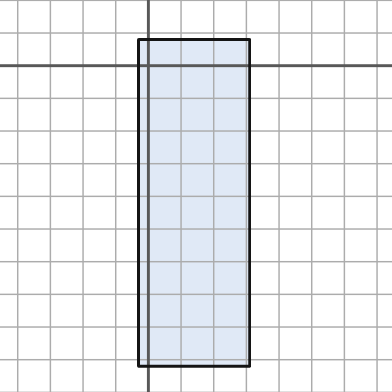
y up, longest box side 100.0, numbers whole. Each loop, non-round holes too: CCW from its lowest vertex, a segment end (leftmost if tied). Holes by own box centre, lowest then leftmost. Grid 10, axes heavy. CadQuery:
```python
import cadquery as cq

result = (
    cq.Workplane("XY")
    .moveTo(-3.0, -92.0)
    .lineTo(31.0, -92.0)
    .lineTo(31.0, 8.0)
    .lineTo(-3.0, 8.0)
    .close()
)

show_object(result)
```